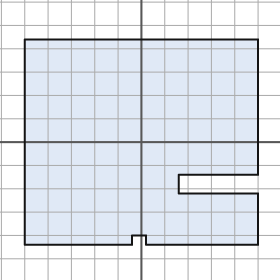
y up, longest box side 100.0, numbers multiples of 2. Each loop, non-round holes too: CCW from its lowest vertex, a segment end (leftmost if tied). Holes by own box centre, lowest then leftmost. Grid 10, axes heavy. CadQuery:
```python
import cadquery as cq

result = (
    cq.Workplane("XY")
    .moveTo(-50.0, -44.0)
    .lineTo(-4.0, -44.0)
    .lineTo(-4.0, -40.0)
    .lineTo(2.0, -40.0)
    .lineTo(2.0, -44.0)
    .lineTo(50.0, -44.0)
    .lineTo(50.0, -22.0)
    .lineTo(16.0, -22.0)
    .lineTo(16.0, -14.0)
    .lineTo(50.0, -14.0)
    .lineTo(50.0, 44.0)
    .lineTo(-50.0, 44.0)
    .close()
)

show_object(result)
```